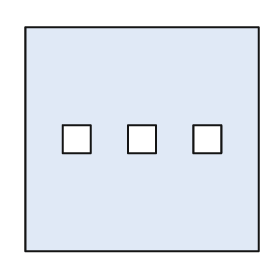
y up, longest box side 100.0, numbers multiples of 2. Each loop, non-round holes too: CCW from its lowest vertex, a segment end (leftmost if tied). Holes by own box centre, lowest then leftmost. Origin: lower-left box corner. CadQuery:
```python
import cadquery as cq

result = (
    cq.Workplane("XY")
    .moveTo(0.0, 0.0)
    .lineTo(100.0, 0.0)
    .lineTo(100.0, 96.0)
    .lineTo(0.0, 96.0)
    .close()
    .moveTo(16.0, 42.0)
    .lineTo(28.0, 42.0)
    .lineTo(28.0, 54.0)
    .lineTo(16.0, 54.0)
    .close()
    .moveTo(44.0, 42.0)
    .lineTo(56.0, 42.0)
    .lineTo(56.0, 54.0)
    .lineTo(44.0, 54.0)
    .close()
    .moveTo(72.0, 42.0)
    .lineTo(84.0, 42.0)
    .lineTo(84.0, 54.0)
    .lineTo(72.0, 54.0)
    .close()
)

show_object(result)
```